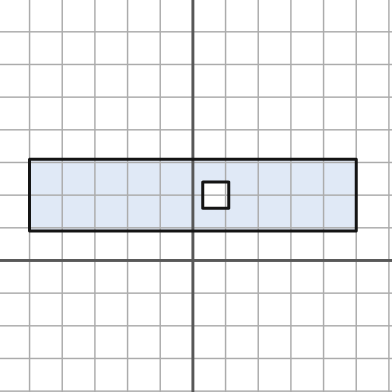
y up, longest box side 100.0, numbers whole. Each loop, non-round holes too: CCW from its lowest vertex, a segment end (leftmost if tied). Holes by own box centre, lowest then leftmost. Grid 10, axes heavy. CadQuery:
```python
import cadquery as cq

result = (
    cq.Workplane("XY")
    .moveTo(-50.0, 9.0)
    .lineTo(50.0, 9.0)
    .lineTo(50.0, 31.0)
    .lineTo(-50.0, 31.0)
    .close()
    .moveTo(3.0, 16.0)
    .lineTo(11.0, 16.0)
    .lineTo(11.0, 24.0)
    .lineTo(3.0, 24.0)
    .close()
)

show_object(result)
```